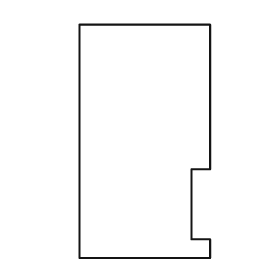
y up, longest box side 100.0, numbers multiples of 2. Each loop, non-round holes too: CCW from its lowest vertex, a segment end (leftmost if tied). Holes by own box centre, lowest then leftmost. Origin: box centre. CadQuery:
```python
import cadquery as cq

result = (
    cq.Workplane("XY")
    .moveTo(-28.0, -50.0)
    .lineTo(28.0, -50.0)
    .lineTo(28.0, -42.0)
    .lineTo(20.0, -42.0)
    .lineTo(20.0, -12.0)
    .lineTo(28.0, -12.0)
    .lineTo(28.0, 50.0)
    .lineTo(-28.0, 50.0)
    .close()
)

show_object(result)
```